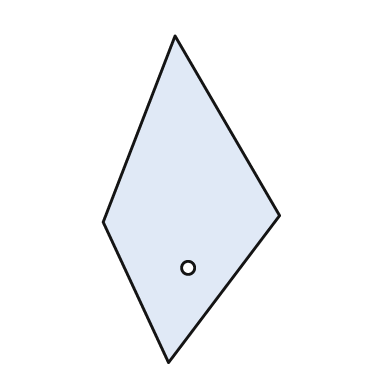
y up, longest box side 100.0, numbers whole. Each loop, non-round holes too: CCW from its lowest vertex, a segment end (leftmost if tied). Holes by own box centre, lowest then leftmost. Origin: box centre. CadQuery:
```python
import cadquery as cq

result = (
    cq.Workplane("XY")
    .moveTo(-7.0, -50.0)
    .lineTo(27.0, -5.0)
    .lineTo(-5.0, 50.0)
    .lineTo(-27.0, -7.0)
    .close()
    .moveTo(-1.0, -21.0)
    .circle(2.0)
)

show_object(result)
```